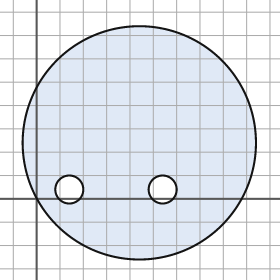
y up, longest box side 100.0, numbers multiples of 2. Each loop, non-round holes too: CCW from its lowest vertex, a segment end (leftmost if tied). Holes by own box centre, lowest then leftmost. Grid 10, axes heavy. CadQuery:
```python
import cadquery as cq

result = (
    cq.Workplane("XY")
    .moveTo(44.0, 24.0)
    .circle(50.0)
    .moveTo(14.0, 4.0)
    .circle(6.0)
    .moveTo(54.0, 4.0)
    .circle(6.0)
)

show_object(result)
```